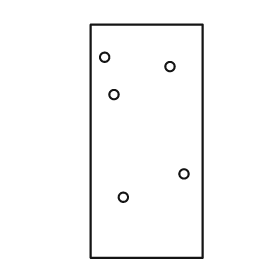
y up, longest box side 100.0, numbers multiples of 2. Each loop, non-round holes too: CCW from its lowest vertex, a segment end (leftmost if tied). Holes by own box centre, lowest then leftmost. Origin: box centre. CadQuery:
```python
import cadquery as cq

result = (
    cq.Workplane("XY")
    .moveTo(-24.0, -50.0)
    .lineTo(24.0, -50.0)
    .lineTo(24.0, 50.0)
    .lineTo(-24.0, 50.0)
    .close()
    .moveTo(-10.0, -24.0)
    .circle(2.0)
    .moveTo(16.0, -14.0)
    .circle(2.0)
    .moveTo(-14.0, 20.0)
    .circle(2.0)
    .moveTo(10.0, 32.0)
    .circle(2.0)
    .moveTo(-18.0, 36.0)
    .circle(2.0)
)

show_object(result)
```